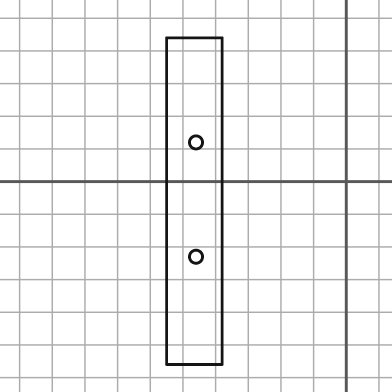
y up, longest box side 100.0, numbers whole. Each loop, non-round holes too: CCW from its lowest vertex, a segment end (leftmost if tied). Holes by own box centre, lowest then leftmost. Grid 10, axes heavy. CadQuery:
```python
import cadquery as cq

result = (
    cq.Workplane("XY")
    .moveTo(-55.0, -56.0)
    .lineTo(-38.0, -56.0)
    .lineTo(-38.0, 44.0)
    .lineTo(-55.0, 44.0)
    .close()
    .moveTo(-46.0, -23.0)
    .circle(2.0)
    .moveTo(-46.0, 12.0)
    .circle(2.0)
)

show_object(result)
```